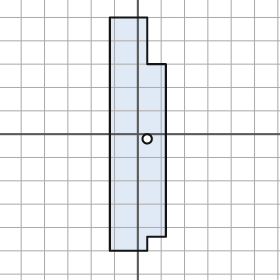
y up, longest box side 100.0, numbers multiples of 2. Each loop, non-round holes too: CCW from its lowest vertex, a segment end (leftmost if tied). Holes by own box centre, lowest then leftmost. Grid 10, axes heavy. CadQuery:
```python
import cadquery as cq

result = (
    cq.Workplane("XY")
    .moveTo(-12.0, -50.0)
    .lineTo(4.0, -50.0)
    .lineTo(4.0, -44.0)
    .lineTo(12.0, -44.0)
    .lineTo(12.0, 30.0)
    .lineTo(4.0, 30.0)
    .lineTo(4.0, 50.0)
    .lineTo(-12.0, 50.0)
    .close()
    .moveTo(4.0, -2.0)
    .circle(2.0)
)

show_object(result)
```